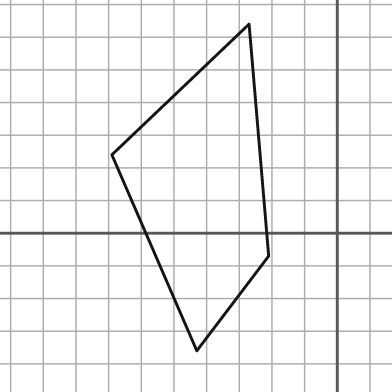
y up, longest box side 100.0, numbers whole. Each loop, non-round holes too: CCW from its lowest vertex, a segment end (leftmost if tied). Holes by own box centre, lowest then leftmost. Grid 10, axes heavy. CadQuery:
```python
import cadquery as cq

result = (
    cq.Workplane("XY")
    .moveTo(-43.0, -36.0)
    .lineTo(-21.0, -7.0)
    .lineTo(-27.0, 64.0)
    .lineTo(-69.0, 24.0)
    .close()
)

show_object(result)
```